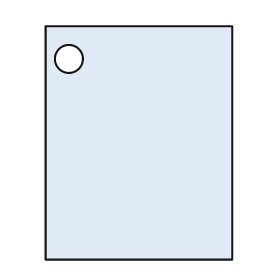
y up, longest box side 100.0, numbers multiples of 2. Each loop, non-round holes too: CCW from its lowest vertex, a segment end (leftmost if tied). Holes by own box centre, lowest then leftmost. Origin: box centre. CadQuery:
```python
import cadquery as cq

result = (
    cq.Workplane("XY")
    .moveTo(-40.0, -50.0)
    .lineTo(40.0, -50.0)
    .lineTo(40.0, 50.0)
    .lineTo(-40.0, 50.0)
    .close()
    .moveTo(-30.0, 36.0)
    .circle(6.0)
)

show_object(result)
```